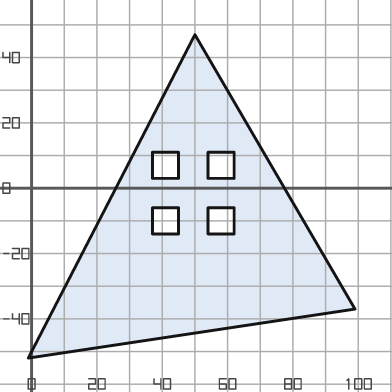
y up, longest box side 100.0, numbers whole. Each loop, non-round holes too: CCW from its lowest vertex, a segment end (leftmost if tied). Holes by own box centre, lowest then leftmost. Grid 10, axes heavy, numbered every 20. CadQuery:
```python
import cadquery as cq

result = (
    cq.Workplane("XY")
    .moveTo(-1.0, -52.0)
    .lineTo(99.0, -37.0)
    .lineTo(50.0, 47.0)
    .close()
    .moveTo(37.0, -14.0)
    .lineTo(45.0, -14.0)
    .lineTo(45.0, -6.0)
    .lineTo(37.0, -6.0)
    .close()
    .moveTo(54.0, -14.0)
    .lineTo(62.0, -14.0)
    .lineTo(62.0, -6.0)
    .lineTo(54.0, -6.0)
    .close()
    .moveTo(37.0, 3.0)
    .lineTo(45.0, 3.0)
    .lineTo(45.0, 11.0)
    .lineTo(37.0, 11.0)
    .close()
    .moveTo(54.0, 3.0)
    .lineTo(62.0, 3.0)
    .lineTo(62.0, 11.0)
    .lineTo(54.0, 11.0)
    .close()
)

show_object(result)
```